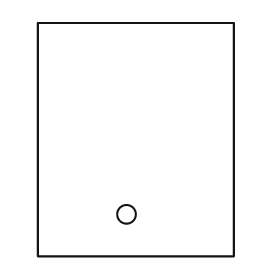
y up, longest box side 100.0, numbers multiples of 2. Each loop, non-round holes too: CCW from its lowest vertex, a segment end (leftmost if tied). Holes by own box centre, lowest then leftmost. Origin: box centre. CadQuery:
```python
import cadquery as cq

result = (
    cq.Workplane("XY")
    .moveTo(-42.0, -50.0)
    .lineTo(42.0, -50.0)
    .lineTo(42.0, 50.0)
    .lineTo(-42.0, 50.0)
    .close()
    .moveTo(-4.0, -32.0)
    .circle(4.0)
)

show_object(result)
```